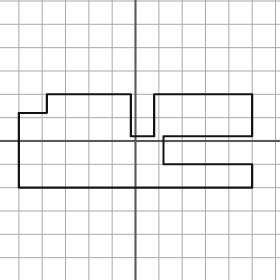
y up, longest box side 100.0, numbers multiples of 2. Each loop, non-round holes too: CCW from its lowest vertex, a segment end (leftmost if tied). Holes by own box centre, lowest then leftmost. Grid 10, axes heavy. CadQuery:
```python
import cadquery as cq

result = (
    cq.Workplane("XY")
    .moveTo(-50.0, -20.0)
    .lineTo(50.0, -20.0)
    .lineTo(50.0, -10.0)
    .lineTo(12.0, -10.0)
    .lineTo(12.0, 2.0)
    .lineTo(50.0, 2.0)
    .lineTo(50.0, 20.0)
    .lineTo(8.0, 20.0)
    .lineTo(8.0, 2.0)
    .lineTo(-2.0, 2.0)
    .lineTo(-2.0, 20.0)
    .lineTo(-38.0, 20.0)
    .lineTo(-38.0, 12.0)
    .lineTo(-50.0, 12.0)
    .close()
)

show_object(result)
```